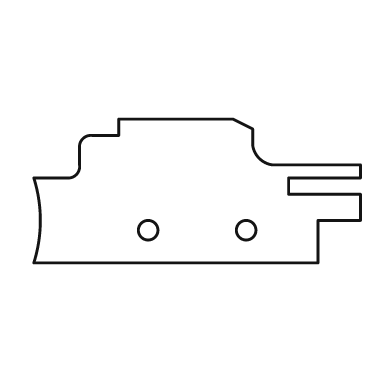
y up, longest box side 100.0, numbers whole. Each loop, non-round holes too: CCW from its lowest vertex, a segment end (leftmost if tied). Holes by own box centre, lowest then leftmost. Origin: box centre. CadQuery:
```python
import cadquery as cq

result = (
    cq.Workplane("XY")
    .moveTo(-50.0, -22.0)
    .lineTo(37.0, -22.0)
    .lineTo(37.0, -9.0)
    .lineTo(50.0, -9.0)
    .lineTo(50.0, -1.0)
    .lineTo(28.0, -1.0)
    .lineTo(28.0, 4.0)
    .lineTo(50.0, 4.0)
    .lineTo(50.0, 8.0)
    .lineTo(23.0, 8.0)
    .threePointArc((19.0, 10.0), (17.0, 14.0))
    .lineTo(17.0, 19.0)
    .lineTo(11.0, 22.0)
    .lineTo(-24.0, 22.0)
    .lineTo(-24.0, 17.0)
    .lineTo(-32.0, 17.0)
    .threePointArc((-35.0, 16.0), (-36.0, 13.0))
    .lineTo(-36.0, 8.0)
    .threePointArc((-37.0, 5.0), (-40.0, 4.0))
    .lineTo(-50.0, 4.0)
    .threePointArc((-48.0, -9.0), (-50.0, -22.0))
    .close()
    .moveTo(-15.0, -12.0)
    .circle(3.0)
    .moveTo(15.0, -12.0)
    .circle(3.0)
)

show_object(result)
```